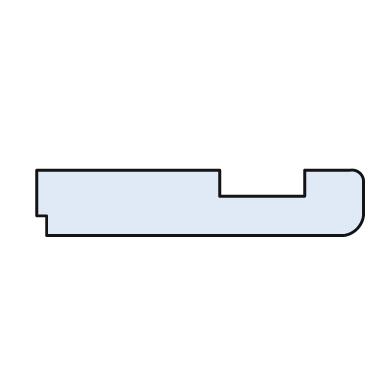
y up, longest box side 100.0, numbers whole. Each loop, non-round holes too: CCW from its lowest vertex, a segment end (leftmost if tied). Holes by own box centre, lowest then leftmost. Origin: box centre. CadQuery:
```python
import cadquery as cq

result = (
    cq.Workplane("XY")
    .moveTo(-47.0, -10.0)
    .lineTo(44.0, -10.0)
    .threePointArc((48.0, -8.0), (50.0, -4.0))
    .lineTo(50.0, 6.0)
    .threePointArc((49.0, 9.0), (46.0, 10.0))
    .lineTo(32.0, 10.0)
    .lineTo(32.0, 2.0)
    .lineTo(6.0, 2.0)
    .lineTo(6.0, 10.0)
    .lineTo(-50.0, 10.0)
    .lineTo(-50.0, -4.0)
    .lineTo(-47.0, -4.0)
    .close()
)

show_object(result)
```